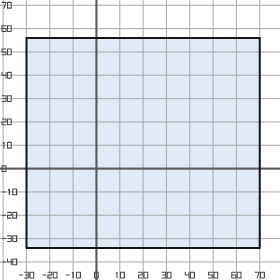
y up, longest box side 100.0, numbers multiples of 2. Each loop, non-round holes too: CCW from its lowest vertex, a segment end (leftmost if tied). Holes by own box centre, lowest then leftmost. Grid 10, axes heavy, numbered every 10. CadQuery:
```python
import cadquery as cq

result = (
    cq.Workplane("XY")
    .moveTo(-30.0, -34.0)
    .lineTo(70.0, -34.0)
    .lineTo(70.0, 56.0)
    .lineTo(-30.0, 56.0)
    .close()
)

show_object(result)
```